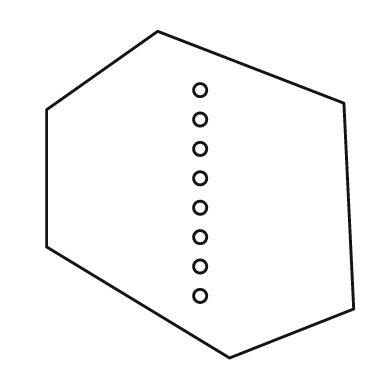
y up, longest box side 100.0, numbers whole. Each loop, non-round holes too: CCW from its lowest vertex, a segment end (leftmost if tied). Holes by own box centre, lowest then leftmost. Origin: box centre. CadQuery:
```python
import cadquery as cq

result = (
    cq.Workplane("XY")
    .moveTo(9.0, -50.0)
    .lineTo(47.0, -35.0)
    .lineTo(44.0, 28.0)
    .lineTo(-13.0, 50.0)
    .lineTo(-47.0, 26.0)
    .lineTo(-47.0, -16.0)
    .close()
    .moveTo(0.0, -31.0)
    .circle(2.0)
    .moveTo(0.0, -22.0)
    .circle(2.0)
    .moveTo(0.0, -13.0)
    .circle(2.0)
    .moveTo(0.0, -4.0)
    .circle(2.0)
    .moveTo(0.0, 5.0)
    .circle(2.0)
    .moveTo(0.0, 14.0)
    .circle(2.0)
    .moveTo(0.0, 23.0)
    .circle(2.0)
    .moveTo(0.0, 32.0)
    .circle(2.0)
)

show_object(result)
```